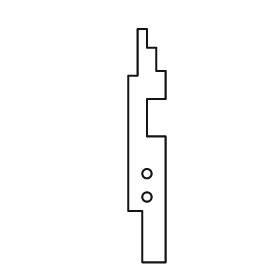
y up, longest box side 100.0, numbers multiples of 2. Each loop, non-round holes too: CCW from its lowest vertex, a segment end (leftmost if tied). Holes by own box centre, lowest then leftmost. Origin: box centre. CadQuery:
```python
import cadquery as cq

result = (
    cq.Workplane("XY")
    .moveTo(-2.0, -50.0)
    .lineTo(8.0, -50.0)
    .lineTo(8.0, 4.0)
    .lineTo(0.0, 4.0)
    .lineTo(0.0, 20.0)
    .lineTo(8.0, 20.0)
    .lineTo(8.0, 32.0)
    .lineTo(4.0, 32.0)
    .lineTo(4.0, 42.0)
    .lineTo(0.0, 42.0)
    .lineTo(0.0, 50.0)
    .lineTo(-4.0, 50.0)
    .lineTo(-4.0, 30.0)
    .lineTo(-8.0, 30.0)
    .lineTo(-8.0, -28.0)
    .lineTo(-2.0, -28.0)
    .close()
    .moveTo(0.0, -22.0)
    .circle(2.0)
    .moveTo(0.0, -12.0)
    .circle(2.0)
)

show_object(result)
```